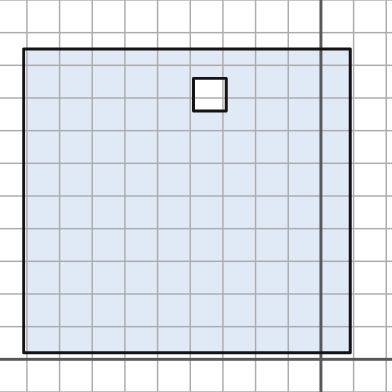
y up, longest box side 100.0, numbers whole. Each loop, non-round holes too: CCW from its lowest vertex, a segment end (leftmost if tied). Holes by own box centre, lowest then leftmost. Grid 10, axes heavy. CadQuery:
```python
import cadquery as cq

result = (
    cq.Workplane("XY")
    .moveTo(-91.0, 2.0)
    .lineTo(9.0, 2.0)
    .lineTo(9.0, 95.0)
    .lineTo(-91.0, 95.0)
    .close()
    .moveTo(-39.0, 76.0)
    .lineTo(-29.0, 76.0)
    .lineTo(-29.0, 86.0)
    .lineTo(-39.0, 86.0)
    .close()
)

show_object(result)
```